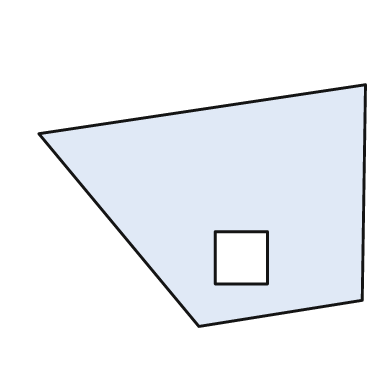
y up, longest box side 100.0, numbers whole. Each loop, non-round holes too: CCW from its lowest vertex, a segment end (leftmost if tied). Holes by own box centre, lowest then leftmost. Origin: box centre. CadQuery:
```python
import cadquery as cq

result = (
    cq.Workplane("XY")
    .moveTo(-1.0, -37.0)
    .lineTo(49.0, -29.0)
    .lineTo(50.0, 37.0)
    .lineTo(-50.0, 22.0)
    .close()
    .moveTo(4.0, -24.0)
    .lineTo(20.0, -24.0)
    .lineTo(20.0, -8.0)
    .lineTo(4.0, -8.0)
    .close()
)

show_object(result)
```